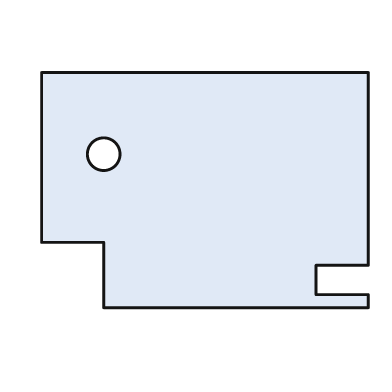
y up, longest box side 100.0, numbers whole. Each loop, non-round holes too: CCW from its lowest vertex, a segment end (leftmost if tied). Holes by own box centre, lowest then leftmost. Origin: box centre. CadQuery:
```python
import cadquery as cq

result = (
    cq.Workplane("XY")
    .moveTo(-31.0, -36.0)
    .lineTo(50.0, -36.0)
    .lineTo(50.0, -32.0)
    .lineTo(34.0, -32.0)
    .lineTo(34.0, -23.0)
    .lineTo(50.0, -23.0)
    .lineTo(50.0, 36.0)
    .lineTo(-50.0, 36.0)
    .lineTo(-50.0, -16.0)
    .lineTo(-31.0, -16.0)
    .close()
    .moveTo(-31.0, 11.0)
    .circle(5.0)
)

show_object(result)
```